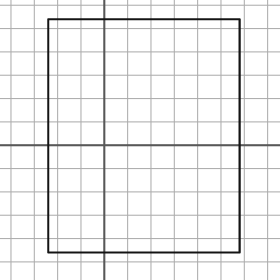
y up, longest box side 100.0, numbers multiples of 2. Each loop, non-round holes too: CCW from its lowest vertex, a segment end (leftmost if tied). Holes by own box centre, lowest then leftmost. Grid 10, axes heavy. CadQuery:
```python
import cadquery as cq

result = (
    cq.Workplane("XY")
    .moveTo(-24.0, -46.0)
    .lineTo(58.0, -46.0)
    .lineTo(58.0, 54.0)
    .lineTo(-24.0, 54.0)
    .close()
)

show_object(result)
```